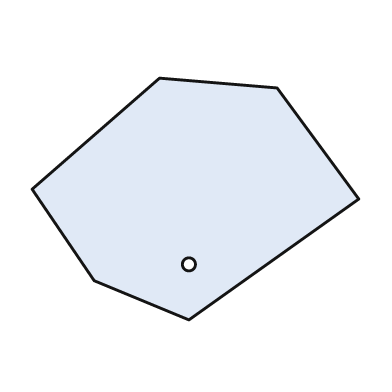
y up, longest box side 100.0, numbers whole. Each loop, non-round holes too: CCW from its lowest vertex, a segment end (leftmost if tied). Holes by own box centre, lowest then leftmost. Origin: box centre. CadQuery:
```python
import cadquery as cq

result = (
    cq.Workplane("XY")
    .moveTo(-2.0, -37.0)
    .lineTo(50.0, 0.0)
    .lineTo(25.0, 34.0)
    .lineTo(-11.0, 37.0)
    .lineTo(-50.0, 3.0)
    .lineTo(-31.0, -25.0)
    .close()
    .moveTo(-2.0, -20.0)
    .circle(2.0)
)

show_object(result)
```